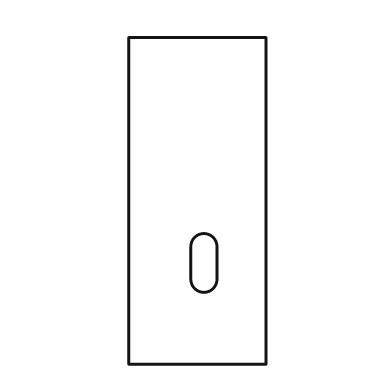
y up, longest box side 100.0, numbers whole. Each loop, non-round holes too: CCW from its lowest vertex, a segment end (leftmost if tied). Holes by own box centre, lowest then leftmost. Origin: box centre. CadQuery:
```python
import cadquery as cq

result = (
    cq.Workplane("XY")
    .moveTo(-21.0, -50.0)
    .lineTo(21.0, -50.0)
    .lineTo(21.0, 50.0)
    .lineTo(-21.0, 50.0)
    .close()
    .moveTo(-2.0, -24.0)
    .threePointArc((2.0, -28.0), (6.0, -24.0))
    .lineTo(6.0, -14.0)
    .threePointArc((2.0, -10.0), (-2.0, -14.0))
    .close()
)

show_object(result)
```